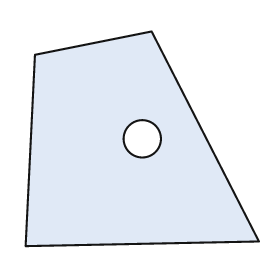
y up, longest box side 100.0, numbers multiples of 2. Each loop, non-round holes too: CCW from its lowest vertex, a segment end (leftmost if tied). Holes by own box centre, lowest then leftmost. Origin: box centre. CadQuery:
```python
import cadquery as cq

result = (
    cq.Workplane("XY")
    .moveTo(-50.0, -46.0)
    .lineTo(50.0, -44.0)
    .lineTo(4.0, 46.0)
    .lineTo(-46.0, 36.0)
    .close()
    .moveTo(0.0, 0.0)
    .circle(8.0)
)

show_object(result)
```